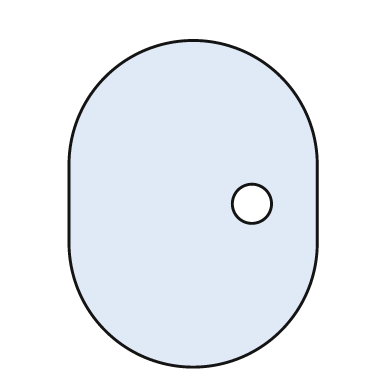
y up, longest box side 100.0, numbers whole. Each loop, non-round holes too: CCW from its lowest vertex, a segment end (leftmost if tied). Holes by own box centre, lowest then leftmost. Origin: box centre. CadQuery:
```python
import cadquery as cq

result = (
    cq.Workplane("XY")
    .moveTo(-38.0, -12.0)
    .threePointArc((0.0, -50.0), (38.0, -12.0))
    .lineTo(38.0, 12.0)
    .threePointArc((0.0, 50.0), (-38.0, 12.0))
    .close()
    .moveTo(18.0, 0.0)
    .circle(6.0)
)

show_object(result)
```